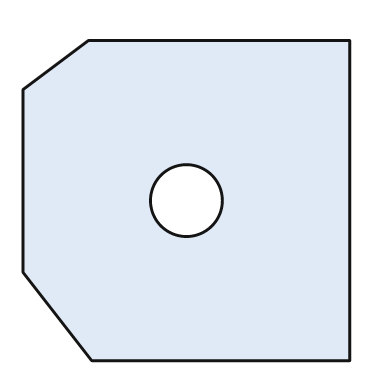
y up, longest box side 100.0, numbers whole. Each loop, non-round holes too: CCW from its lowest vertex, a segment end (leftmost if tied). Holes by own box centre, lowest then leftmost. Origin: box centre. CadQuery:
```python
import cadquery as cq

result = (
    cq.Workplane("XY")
    .moveTo(-29.0, -49.0)
    .lineTo(50.0, -49.0)
    .lineTo(50.0, 49.0)
    .lineTo(-30.0, 49.0)
    .lineTo(-50.0, 34.0)
    .lineTo(-50.0, -22.0)
    .close()
    .moveTo(0.0, 0.0)
    .circle(11.0)
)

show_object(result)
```